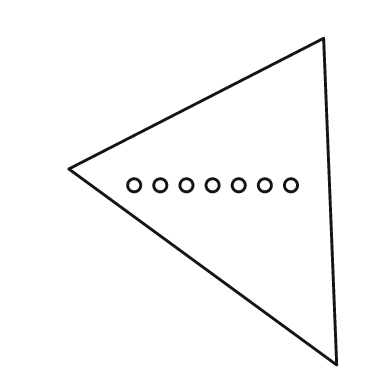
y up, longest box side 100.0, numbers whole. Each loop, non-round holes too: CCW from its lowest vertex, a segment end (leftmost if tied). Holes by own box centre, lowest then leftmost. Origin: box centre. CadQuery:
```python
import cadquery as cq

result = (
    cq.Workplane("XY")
    .moveTo(41.0, -50.0)
    .lineTo(37.0, 50.0)
    .lineTo(-41.0, 10.0)
    .close()
    .moveTo(-21.0, 5.0)
    .circle(2.0)
    .moveTo(-13.0, 5.0)
    .circle(2.0)
    .moveTo(-5.0, 5.0)
    .circle(2.0)
    .moveTo(3.0, 5.0)
    .circle(2.0)
    .moveTo(11.0, 5.0)
    .circle(2.0)
    .moveTo(19.0, 5.0)
    .circle(2.0)
    .moveTo(27.0, 5.0)
    .circle(2.0)
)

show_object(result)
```